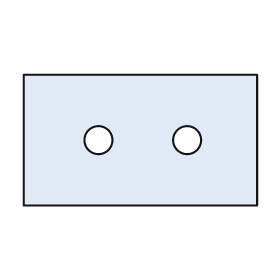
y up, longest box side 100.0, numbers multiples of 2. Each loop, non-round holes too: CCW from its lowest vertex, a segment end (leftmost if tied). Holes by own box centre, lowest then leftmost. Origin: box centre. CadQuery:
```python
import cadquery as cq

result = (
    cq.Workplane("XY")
    .moveTo(-50.0, -28.0)
    .lineTo(50.0, -28.0)
    .lineTo(50.0, 28.0)
    .lineTo(-50.0, 28.0)
    .close()
    .moveTo(-18.0, 0.0)
    .circle(6.0)
    .moveTo(20.0, 0.0)
    .circle(6.0)
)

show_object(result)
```